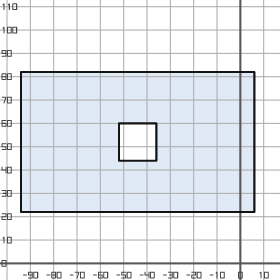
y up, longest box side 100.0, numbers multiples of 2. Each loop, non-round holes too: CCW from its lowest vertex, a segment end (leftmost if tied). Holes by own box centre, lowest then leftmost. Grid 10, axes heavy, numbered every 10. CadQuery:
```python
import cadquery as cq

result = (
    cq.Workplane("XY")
    .moveTo(-94.0, 22.0)
    .lineTo(6.0, 22.0)
    .lineTo(6.0, 82.0)
    .lineTo(-94.0, 82.0)
    .close()
    .moveTo(-52.0, 44.0)
    .lineTo(-36.0, 44.0)
    .lineTo(-36.0, 60.0)
    .lineTo(-52.0, 60.0)
    .close()
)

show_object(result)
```